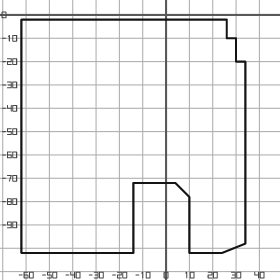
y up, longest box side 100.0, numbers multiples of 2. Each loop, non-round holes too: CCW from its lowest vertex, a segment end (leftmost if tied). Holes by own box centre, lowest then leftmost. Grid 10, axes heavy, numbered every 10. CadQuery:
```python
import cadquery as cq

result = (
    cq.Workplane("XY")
    .moveTo(-62.0, -102.0)
    .lineTo(-14.0, -102.0)
    .lineTo(-14.0, -72.0)
    .lineTo(4.0, -72.0)
    .lineTo(10.0, -78.0)
    .lineTo(10.0, -102.0)
    .lineTo(24.0, -102.0)
    .lineTo(34.0, -98.0)
    .lineTo(34.0, -20.0)
    .lineTo(30.0, -20.0)
    .lineTo(30.0, -10.0)
    .lineTo(26.0, -10.0)
    .lineTo(26.0, -2.0)
    .lineTo(-62.0, -2.0)
    .close()
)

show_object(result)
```